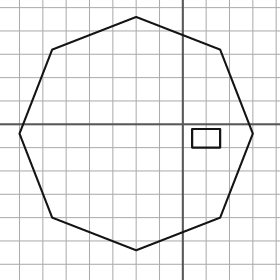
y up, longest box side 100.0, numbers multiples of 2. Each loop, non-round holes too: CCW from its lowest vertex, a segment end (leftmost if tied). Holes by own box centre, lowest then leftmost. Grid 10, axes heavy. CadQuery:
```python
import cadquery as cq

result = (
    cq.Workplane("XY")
    .moveTo(-20.0, -54.0)
    .lineTo(16.0, -40.0)
    .lineTo(30.0, -4.0)
    .lineTo(16.0, 32.0)
    .lineTo(-20.0, 46.0)
    .lineTo(-56.0, 32.0)
    .lineTo(-70.0, -4.0)
    .lineTo(-56.0, -40.0)
    .close()
    .moveTo(4.0, -10.0)
    .lineTo(16.0, -10.0)
    .lineTo(16.0, -2.0)
    .lineTo(4.0, -2.0)
    .close()
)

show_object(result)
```